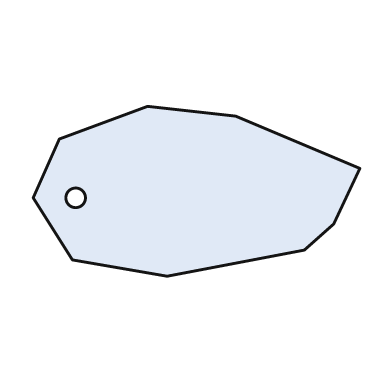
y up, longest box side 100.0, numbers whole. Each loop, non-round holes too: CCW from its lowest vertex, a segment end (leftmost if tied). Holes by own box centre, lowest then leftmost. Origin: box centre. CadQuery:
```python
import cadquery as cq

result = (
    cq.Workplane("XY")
    .moveTo(-9.0, -26.0)
    .lineTo(33.0, -18.0)
    .lineTo(42.0, -10.0)
    .lineTo(50.0, 7.0)
    .lineTo(12.0, 23.0)
    .lineTo(-15.0, 26.0)
    .lineTo(-42.0, 16.0)
    .lineTo(-50.0, -2.0)
    .lineTo(-38.0, -21.0)
    .close()
    .moveTo(-37.0, -2.0)
    .circle(3.0)
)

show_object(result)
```